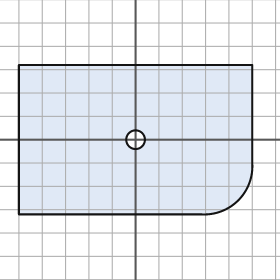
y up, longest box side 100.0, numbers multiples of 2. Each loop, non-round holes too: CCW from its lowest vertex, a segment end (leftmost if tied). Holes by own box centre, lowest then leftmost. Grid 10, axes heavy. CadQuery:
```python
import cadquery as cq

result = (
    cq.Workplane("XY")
    .moveTo(-50.0, -32.0)
    .lineTo(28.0, -32.0)
    .threePointArc((44.0, -26.0), (50.0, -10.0))
    .lineTo(50.0, 32.0)
    .lineTo(-50.0, 32.0)
    .close()
    .moveTo(0.0, 0.0)
    .circle(4.0)
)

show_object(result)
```